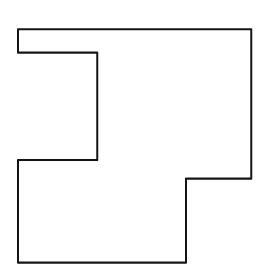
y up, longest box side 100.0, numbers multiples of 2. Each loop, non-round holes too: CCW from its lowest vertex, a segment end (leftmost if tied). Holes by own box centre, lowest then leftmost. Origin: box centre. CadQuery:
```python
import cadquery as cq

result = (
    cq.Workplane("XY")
    .moveTo(-50.0, -50.0)
    .lineTo(22.0, -50.0)
    .lineTo(22.0, -14.0)
    .lineTo(50.0, -14.0)
    .lineTo(50.0, 50.0)
    .lineTo(-50.0, 50.0)
    .lineTo(-50.0, 40.0)
    .lineTo(-16.0, 40.0)
    .lineTo(-16.0, -6.0)
    .lineTo(-50.0, -6.0)
    .close()
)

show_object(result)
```